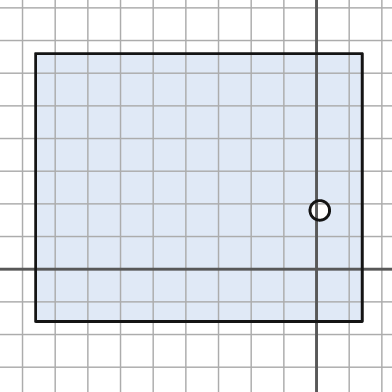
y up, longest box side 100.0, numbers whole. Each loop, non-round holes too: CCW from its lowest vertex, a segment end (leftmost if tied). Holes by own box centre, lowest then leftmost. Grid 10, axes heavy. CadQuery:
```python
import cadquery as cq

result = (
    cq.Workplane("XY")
    .moveTo(-86.0, -16.0)
    .lineTo(14.0, -16.0)
    .lineTo(14.0, 66.0)
    .lineTo(-86.0, 66.0)
    .close()
    .moveTo(1.0, 18.0)
    .circle(3.0)
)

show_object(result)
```